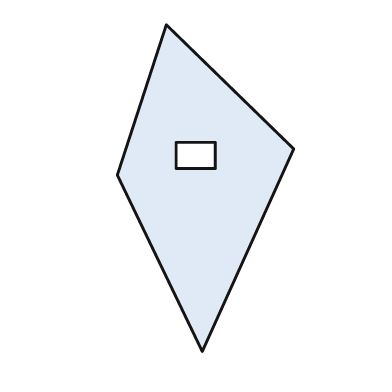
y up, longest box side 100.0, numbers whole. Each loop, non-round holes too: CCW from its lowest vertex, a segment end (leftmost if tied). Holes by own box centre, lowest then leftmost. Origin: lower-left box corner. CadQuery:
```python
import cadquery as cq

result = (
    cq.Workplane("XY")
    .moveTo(26.0, 0.0)
    .lineTo(54.0, 62.0)
    .lineTo(15.0, 100.0)
    .lineTo(0.0, 54.0)
    .close()
    .moveTo(18.0, 56.0)
    .lineTo(30.0, 56.0)
    .lineTo(30.0, 64.0)
    .lineTo(18.0, 64.0)
    .close()
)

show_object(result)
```